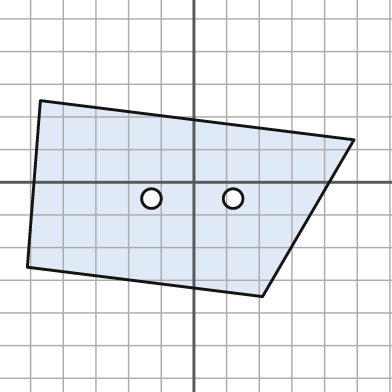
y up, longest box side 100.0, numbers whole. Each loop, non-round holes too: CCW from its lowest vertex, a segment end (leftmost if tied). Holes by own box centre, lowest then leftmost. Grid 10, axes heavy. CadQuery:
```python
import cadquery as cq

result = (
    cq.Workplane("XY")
    .moveTo(21.0, -35.0)
    .lineTo(49.0, 13.0)
    .lineTo(-47.0, 25.0)
    .lineTo(-51.0, -26.0)
    .close()
    .moveTo(-13.0, -5.0)
    .circle(3.0)
    .moveTo(12.0, -5.0)
    .circle(3.0)
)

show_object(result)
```